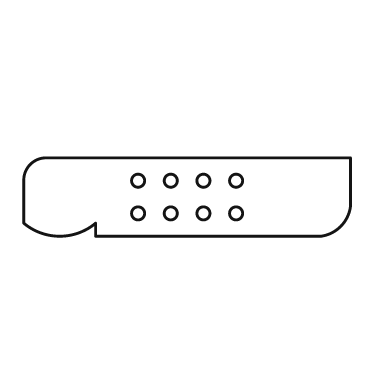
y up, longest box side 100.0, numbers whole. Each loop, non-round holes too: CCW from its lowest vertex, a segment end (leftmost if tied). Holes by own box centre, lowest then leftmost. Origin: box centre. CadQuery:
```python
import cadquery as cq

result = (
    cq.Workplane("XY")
    .moveTo(-28.0, -12.0)
    .lineTo(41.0, -12.0)
    .threePointArc((47.0, -9.0), (50.0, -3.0))
    .lineTo(50.0, 12.0)
    .lineTo(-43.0, 12.0)
    .threePointArc((-48.0, 10.0), (-50.0, 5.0))
    .lineTo(-50.0, -8.0)
    .threePointArc((-39.0, -12.0), (-28.0, -8.0))
    .close()
    .moveTo(-15.0, -5.0)
    .circle(2.0)
    .moveTo(-5.0, -5.0)
    .circle(2.0)
    .moveTo(5.0, -5.0)
    .circle(2.0)
    .moveTo(15.0, -5.0)
    .circle(2.0)
    .moveTo(-15.0, 5.0)
    .circle(2.0)
    .moveTo(-5.0, 5.0)
    .circle(2.0)
    .moveTo(5.0, 5.0)
    .circle(2.0)
    .moveTo(15.0, 5.0)
    .circle(2.0)
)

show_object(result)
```